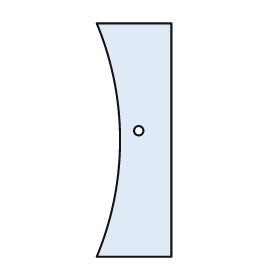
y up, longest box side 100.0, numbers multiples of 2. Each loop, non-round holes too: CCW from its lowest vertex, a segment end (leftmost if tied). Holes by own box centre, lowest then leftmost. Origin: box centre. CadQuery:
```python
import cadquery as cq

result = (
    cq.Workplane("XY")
    .moveTo(-16.0, -50.0)
    .lineTo(16.0, -50.0)
    .lineTo(16.0, 50.0)
    .lineTo(-16.0, 50.0)
    .threePointArc((-6.0, 0.0), (-16.0, -50.0))
    .close()
    .moveTo(2.0, 4.0)
    .circle(2.0)
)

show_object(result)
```